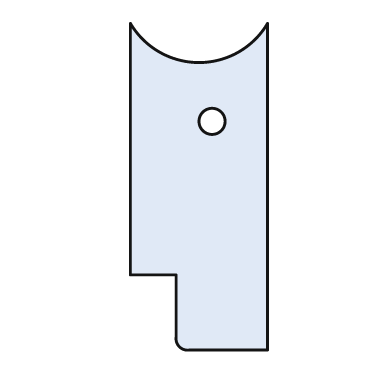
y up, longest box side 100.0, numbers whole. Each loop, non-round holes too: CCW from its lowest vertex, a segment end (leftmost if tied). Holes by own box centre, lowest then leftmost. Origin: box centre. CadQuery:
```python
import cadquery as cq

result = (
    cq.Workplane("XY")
    .moveTo(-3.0, -50.0)
    .lineTo(21.0, -50.0)
    .lineTo(21.0, 50.0)
    .threePointArc((0.0, 38.0), (-21.0, 50.0))
    .lineTo(-21.0, -27.0)
    .lineTo(-7.0, -27.0)
    .lineTo(-7.0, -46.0)
    .threePointArc((-6.0, -49.0), (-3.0, -50.0))
    .close()
    .moveTo(4.0, 20.0)
    .circle(4.0)
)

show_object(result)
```